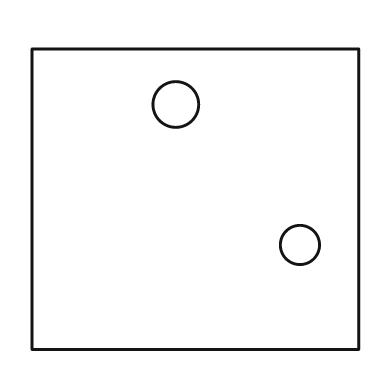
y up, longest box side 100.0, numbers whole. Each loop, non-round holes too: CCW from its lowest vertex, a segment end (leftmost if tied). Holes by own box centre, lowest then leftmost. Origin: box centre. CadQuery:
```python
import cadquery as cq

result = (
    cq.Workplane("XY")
    .moveTo(-50.0, -46.0)
    .lineTo(50.0, -46.0)
    .lineTo(50.0, 46.0)
    .lineTo(-50.0, 46.0)
    .close()
    .moveTo(32.0, -14.0)
    .circle(6.0)
    .moveTo(-6.0, 29.0)
    .circle(7.0)
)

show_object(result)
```